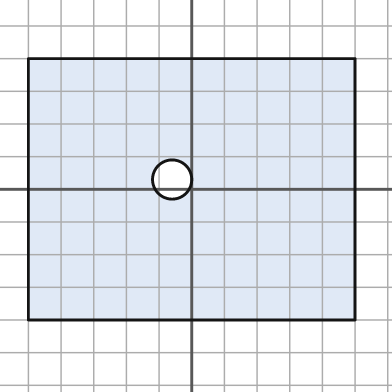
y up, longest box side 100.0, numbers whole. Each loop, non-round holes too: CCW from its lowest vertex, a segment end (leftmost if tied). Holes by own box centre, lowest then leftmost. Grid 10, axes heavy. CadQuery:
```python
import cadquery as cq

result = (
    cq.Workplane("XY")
    .moveTo(-50.0, -40.0)
    .lineTo(50.0, -40.0)
    .lineTo(50.0, 40.0)
    .lineTo(-50.0, 40.0)
    .close()
    .moveTo(-6.0, 3.0)
    .circle(6.0)
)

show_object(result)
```